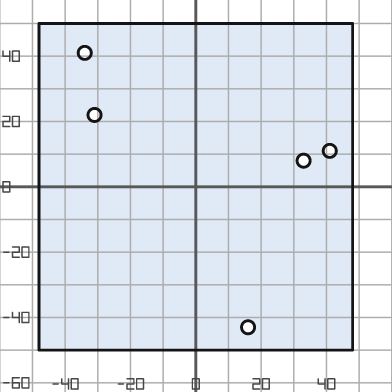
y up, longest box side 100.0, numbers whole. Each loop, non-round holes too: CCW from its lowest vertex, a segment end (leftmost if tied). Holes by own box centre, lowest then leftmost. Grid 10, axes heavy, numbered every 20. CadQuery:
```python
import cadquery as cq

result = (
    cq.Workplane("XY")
    .moveTo(-48.0, -50.0)
    .lineTo(48.0, -50.0)
    .lineTo(48.0, 50.0)
    .lineTo(-48.0, 50.0)
    .close()
    .moveTo(16.0, -43.0)
    .circle(2.0)
    .moveTo(33.0, 8.0)
    .circle(2.0)
    .moveTo(41.0, 11.0)
    .circle(2.0)
    .moveTo(-31.0, 22.0)
    .circle(2.0)
    .moveTo(-34.0, 41.0)
    .circle(2.0)
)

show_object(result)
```